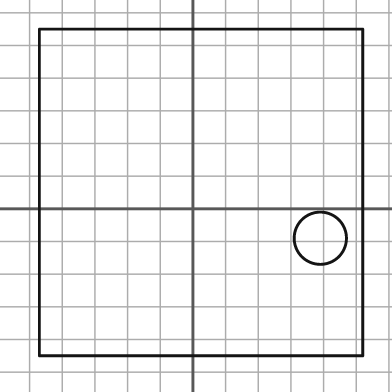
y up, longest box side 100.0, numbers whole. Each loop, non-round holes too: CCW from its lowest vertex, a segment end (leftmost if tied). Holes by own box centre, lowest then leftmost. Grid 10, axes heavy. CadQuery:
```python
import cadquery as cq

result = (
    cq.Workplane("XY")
    .moveTo(-47.0, -45.0)
    .lineTo(52.0, -45.0)
    .lineTo(52.0, 55.0)
    .lineTo(-47.0, 55.0)
    .close()
    .moveTo(39.0, -9.0)
    .circle(8.0)
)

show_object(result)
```